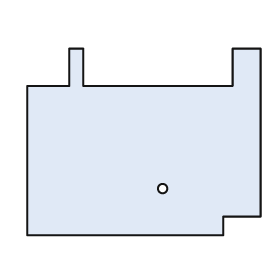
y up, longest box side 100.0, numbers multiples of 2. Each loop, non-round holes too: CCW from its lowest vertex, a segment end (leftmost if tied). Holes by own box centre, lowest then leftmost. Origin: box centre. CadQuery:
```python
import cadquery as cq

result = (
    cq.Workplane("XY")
    .moveTo(-50.0, -40.0)
    .lineTo(34.0, -40.0)
    .lineTo(34.0, -32.0)
    .lineTo(50.0, -32.0)
    .lineTo(50.0, 40.0)
    .lineTo(38.0, 40.0)
    .lineTo(38.0, 24.0)
    .lineTo(-26.0, 24.0)
    .lineTo(-26.0, 40.0)
    .lineTo(-32.0, 40.0)
    .lineTo(-32.0, 24.0)
    .lineTo(-50.0, 24.0)
    .close()
    .moveTo(8.0, -20.0)
    .circle(2.0)
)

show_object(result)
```